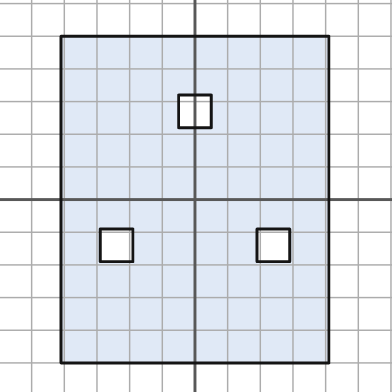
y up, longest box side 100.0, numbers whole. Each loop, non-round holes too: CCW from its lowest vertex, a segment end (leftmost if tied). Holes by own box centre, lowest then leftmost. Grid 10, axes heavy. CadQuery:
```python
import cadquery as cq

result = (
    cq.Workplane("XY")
    .moveTo(-41.0, -50.0)
    .lineTo(41.0, -50.0)
    .lineTo(41.0, 50.0)
    .lineTo(-41.0, 50.0)
    .close()
    .moveTo(-29.0, -19.0)
    .lineTo(-19.0, -19.0)
    .lineTo(-19.0, -9.0)
    .lineTo(-29.0, -9.0)
    .close()
    .moveTo(19.0, -19.0)
    .lineTo(29.0, -19.0)
    .lineTo(29.0, -9.0)
    .lineTo(19.0, -9.0)
    .close()
    .moveTo(-5.0, 22.0)
    .lineTo(5.0, 22.0)
    .lineTo(5.0, 32.0)
    .lineTo(-5.0, 32.0)
    .close()
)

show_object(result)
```